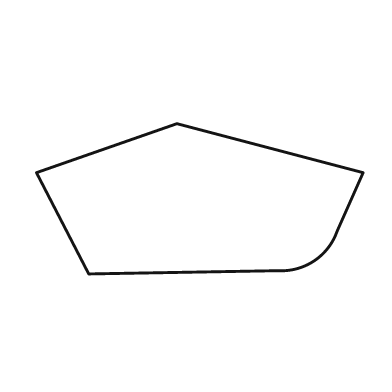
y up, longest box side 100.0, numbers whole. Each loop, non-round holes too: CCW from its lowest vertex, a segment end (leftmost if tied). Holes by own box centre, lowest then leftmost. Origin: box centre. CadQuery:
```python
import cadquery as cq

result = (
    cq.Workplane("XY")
    .moveTo(-34.0, -23.0)
    .lineTo(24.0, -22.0)
    .threePointArc((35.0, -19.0), (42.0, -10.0))
    .lineTo(50.0, 8.0)
    .lineTo(-7.0, 23.0)
    .lineTo(-50.0, 8.0)
    .close()
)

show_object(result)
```